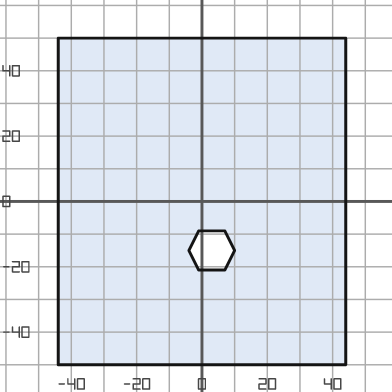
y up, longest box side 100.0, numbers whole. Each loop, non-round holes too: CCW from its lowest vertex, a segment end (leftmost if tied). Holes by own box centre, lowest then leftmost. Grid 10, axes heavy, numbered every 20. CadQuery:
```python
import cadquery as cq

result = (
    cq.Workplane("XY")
    .moveTo(-44.0, -50.0)
    .lineTo(44.0, -50.0)
    .lineTo(44.0, 50.0)
    .lineTo(-44.0, 50.0)
    .close()
    .moveTo(-1.0, -21.0)
    .lineTo(7.0, -21.0)
    .lineTo(10.0, -15.0)
    .lineTo(7.0, -9.0)
    .lineTo(-1.0, -9.0)
    .lineTo(-4.0, -15.0)
    .close()
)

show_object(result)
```